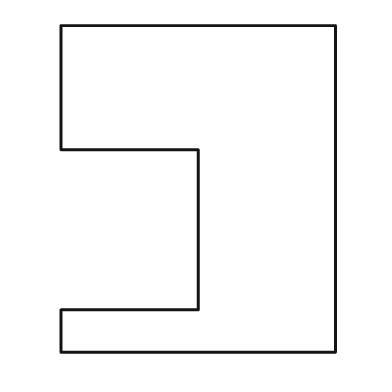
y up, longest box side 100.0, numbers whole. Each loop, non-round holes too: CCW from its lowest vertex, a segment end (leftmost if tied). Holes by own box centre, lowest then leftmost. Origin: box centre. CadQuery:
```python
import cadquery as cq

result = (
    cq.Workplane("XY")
    .moveTo(-42.0, -50.0)
    .lineTo(42.0, -50.0)
    .lineTo(42.0, 50.0)
    .lineTo(-42.0, 50.0)
    .lineTo(-42.0, 12.0)
    .lineTo(0.0, 12.0)
    .lineTo(0.0, -37.0)
    .lineTo(-42.0, -37.0)
    .close()
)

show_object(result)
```